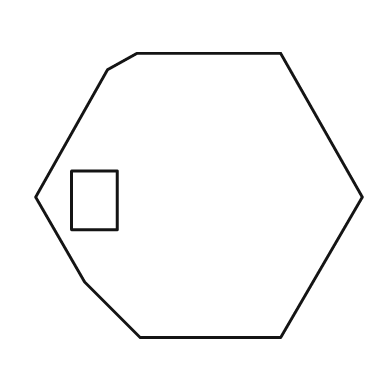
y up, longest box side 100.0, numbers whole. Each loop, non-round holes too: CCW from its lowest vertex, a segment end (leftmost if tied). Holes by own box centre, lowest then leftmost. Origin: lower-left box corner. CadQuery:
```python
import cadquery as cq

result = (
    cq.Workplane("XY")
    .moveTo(32.0, 0.0)
    .lineTo(75.0, 0.0)
    .lineTo(100.0, 43.0)
    .lineTo(75.0, 87.0)
    .lineTo(31.0, 87.0)
    .lineTo(22.0, 82.0)
    .lineTo(0.0, 43.0)
    .lineTo(15.0, 17.0)
    .close()
    .moveTo(11.0, 33.0)
    .lineTo(25.0, 33.0)
    .lineTo(25.0, 51.0)
    .lineTo(11.0, 51.0)
    .close()
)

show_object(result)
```